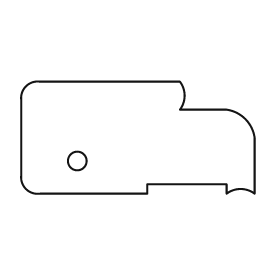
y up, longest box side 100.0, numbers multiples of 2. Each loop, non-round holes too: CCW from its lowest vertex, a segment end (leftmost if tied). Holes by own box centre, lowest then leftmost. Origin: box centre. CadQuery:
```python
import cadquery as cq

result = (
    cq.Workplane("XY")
    .moveTo(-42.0, -24.0)
    .lineTo(4.0, -24.0)
    .lineTo(4.0, -20.0)
    .lineTo(38.0, -20.0)
    .lineTo(38.0, -24.0)
    .threePointArc((44.0, -22.0), (50.0, -24.0))
    .lineTo(50.0, 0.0)
    .threePointArc((46.0, 8.0), (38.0, 12.0))
    .lineTo(18.0, 12.0)
    .threePointArc((20.0, 18.0), (18.0, 24.0))
    .lineTo(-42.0, 24.0)
    .threePointArc((-48.0, 22.0), (-50.0, 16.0))
    .lineTo(-50.0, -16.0)
    .threePointArc((-48.0, -22.0), (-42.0, -24.0))
    .close()
    .moveTo(-26.0, -10.0)
    .circle(4.0)
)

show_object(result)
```